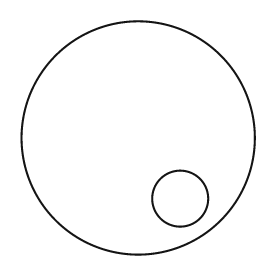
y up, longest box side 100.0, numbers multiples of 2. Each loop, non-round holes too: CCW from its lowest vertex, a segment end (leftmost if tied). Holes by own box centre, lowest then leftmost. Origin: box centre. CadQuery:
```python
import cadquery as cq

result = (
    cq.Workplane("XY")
    .moveTo(0.0, 0.0)
    .circle(50.0)
    .moveTo(18.0, -26.0)
    .circle(12.0)
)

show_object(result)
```